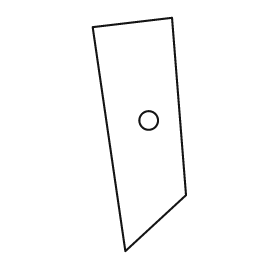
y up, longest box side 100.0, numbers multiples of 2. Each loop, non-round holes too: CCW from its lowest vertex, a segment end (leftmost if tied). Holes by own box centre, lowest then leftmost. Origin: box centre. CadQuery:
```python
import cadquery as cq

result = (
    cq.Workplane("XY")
    .moveTo(-6.0, -50.0)
    .lineTo(20.0, -26.0)
    .lineTo(14.0, 50.0)
    .lineTo(-20.0, 46.0)
    .close()
    .moveTo(4.0, 6.0)
    .circle(4.0)
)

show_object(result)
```